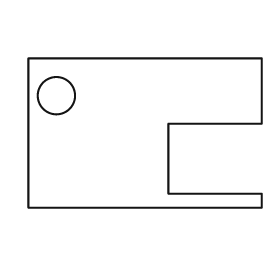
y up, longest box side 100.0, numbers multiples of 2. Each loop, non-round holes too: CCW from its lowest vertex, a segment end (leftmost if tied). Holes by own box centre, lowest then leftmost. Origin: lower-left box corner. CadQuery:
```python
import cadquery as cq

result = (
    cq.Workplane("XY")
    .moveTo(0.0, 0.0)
    .lineTo(100.0, 0.0)
    .lineTo(100.0, 6.0)
    .lineTo(60.0, 6.0)
    .lineTo(60.0, 36.0)
    .lineTo(100.0, 36.0)
    .lineTo(100.0, 64.0)
    .lineTo(0.0, 64.0)
    .close()
    .moveTo(12.0, 48.0)
    .circle(8.0)
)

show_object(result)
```